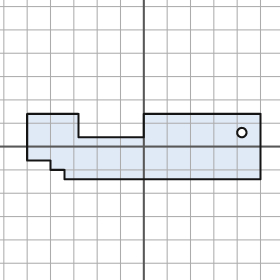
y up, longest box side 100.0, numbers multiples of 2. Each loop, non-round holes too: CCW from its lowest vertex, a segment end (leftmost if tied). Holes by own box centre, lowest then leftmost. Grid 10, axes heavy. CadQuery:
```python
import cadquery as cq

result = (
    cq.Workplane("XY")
    .moveTo(-34.0, -14.0)
    .lineTo(50.0, -14.0)
    .lineTo(50.0, 14.0)
    .lineTo(0.0, 14.0)
    .lineTo(0.0, 4.0)
    .lineTo(-28.0, 4.0)
    .lineTo(-28.0, 14.0)
    .lineTo(-50.0, 14.0)
    .lineTo(-50.0, -6.0)
    .lineTo(-40.0, -6.0)
    .lineTo(-40.0, -10.0)
    .lineTo(-34.0, -10.0)
    .close()
    .moveTo(42.0, 6.0)
    .circle(2.0)
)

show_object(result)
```